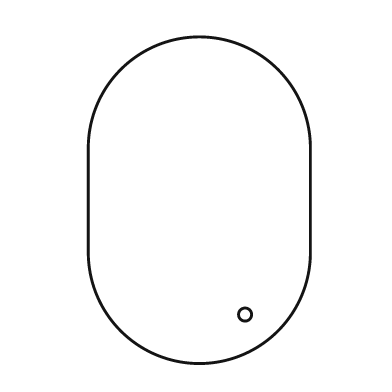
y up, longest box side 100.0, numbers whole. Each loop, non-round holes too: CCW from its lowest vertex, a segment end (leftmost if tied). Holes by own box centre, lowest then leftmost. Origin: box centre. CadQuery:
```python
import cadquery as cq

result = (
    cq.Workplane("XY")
    .moveTo(-34.0, -16.0)
    .threePointArc((0.0, -50.0), (34.0, -16.0))
    .lineTo(34.0, 16.0)
    .threePointArc((0.0, 50.0), (-34.0, 16.0))
    .close()
    .moveTo(14.0, -35.0)
    .circle(2.0)
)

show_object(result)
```